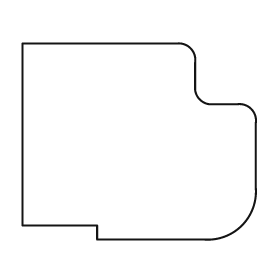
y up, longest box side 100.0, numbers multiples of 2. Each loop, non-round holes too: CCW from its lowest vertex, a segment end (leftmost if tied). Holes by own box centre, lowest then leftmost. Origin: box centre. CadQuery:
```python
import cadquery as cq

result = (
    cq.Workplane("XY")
    .moveTo(-18.0, -42.0)
    .lineTo(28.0, -42.0)
    .threePointArc((44.0, -36.0), (50.0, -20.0))
    .lineTo(50.0, 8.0)
    .threePointArc((48.0, 14.0), (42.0, 16.0))
    .lineTo(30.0, 16.0)
    .threePointArc((26.0, 18.0), (24.0, 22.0))
    .lineTo(24.0, 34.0)
    .threePointArc((22.0, 40.0), (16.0, 42.0))
    .lineTo(-50.0, 42.0)
    .lineTo(-50.0, -36.0)
    .lineTo(-18.0, -36.0)
    .close()
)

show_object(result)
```